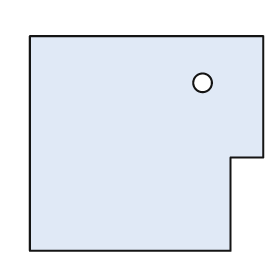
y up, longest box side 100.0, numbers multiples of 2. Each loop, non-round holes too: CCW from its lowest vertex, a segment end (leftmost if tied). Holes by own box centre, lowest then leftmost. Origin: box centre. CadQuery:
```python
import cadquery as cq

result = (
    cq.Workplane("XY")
    .moveTo(-50.0, -46.0)
    .lineTo(36.0, -46.0)
    .lineTo(36.0, -6.0)
    .lineTo(50.0, -6.0)
    .lineTo(50.0, 46.0)
    .lineTo(-50.0, 46.0)
    .close()
    .moveTo(24.0, 26.0)
    .circle(4.0)
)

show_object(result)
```